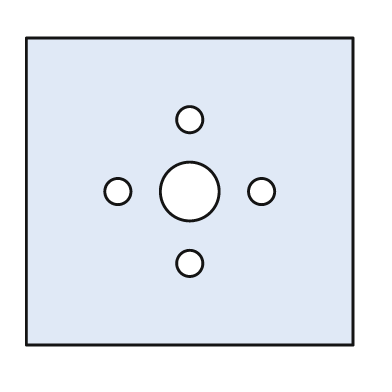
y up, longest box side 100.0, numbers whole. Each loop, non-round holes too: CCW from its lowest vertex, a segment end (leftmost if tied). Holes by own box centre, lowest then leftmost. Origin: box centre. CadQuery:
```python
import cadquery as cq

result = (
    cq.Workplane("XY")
    .moveTo(-50.0, -47.0)
    .lineTo(50.0, -47.0)
    .lineTo(50.0, 47.0)
    .lineTo(-50.0, 47.0)
    .close()
    .moveTo(0.0, -22.0)
    .circle(4.0)
    .moveTo(-22.0, 0.0)
    .circle(4.0)
    .moveTo(0.0, 0.0)
    .circle(9.0)
    .moveTo(22.0, 0.0)
    .circle(4.0)
    .moveTo(0.0, 22.0)
    .circle(4.0)
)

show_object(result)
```